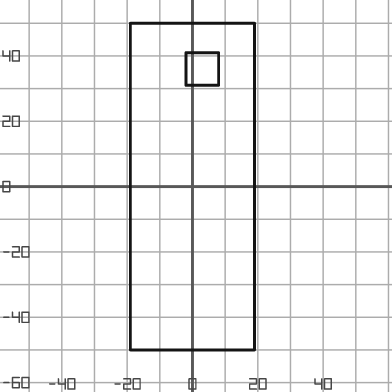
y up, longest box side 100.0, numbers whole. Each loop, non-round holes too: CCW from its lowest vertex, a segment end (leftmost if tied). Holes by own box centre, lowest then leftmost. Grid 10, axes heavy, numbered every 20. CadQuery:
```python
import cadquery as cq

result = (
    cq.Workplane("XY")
    .moveTo(-19.0, -50.0)
    .lineTo(19.0, -50.0)
    .lineTo(19.0, 50.0)
    .lineTo(-19.0, 50.0)
    .close()
    .moveTo(-2.0, 31.0)
    .lineTo(8.0, 31.0)
    .lineTo(8.0, 41.0)
    .lineTo(-2.0, 41.0)
    .close()
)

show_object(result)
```